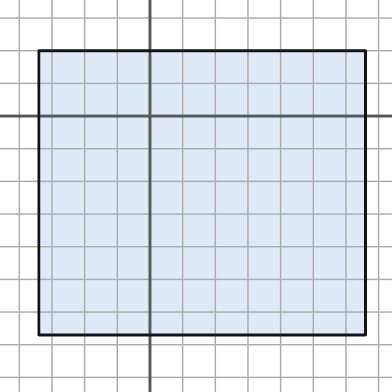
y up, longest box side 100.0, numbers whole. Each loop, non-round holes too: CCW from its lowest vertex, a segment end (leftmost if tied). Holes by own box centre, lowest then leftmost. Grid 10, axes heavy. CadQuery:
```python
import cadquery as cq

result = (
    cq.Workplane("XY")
    .moveTo(-34.0, -67.0)
    .lineTo(66.0, -67.0)
    .lineTo(66.0, 20.0)
    .lineTo(-34.0, 20.0)
    .close()
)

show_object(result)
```